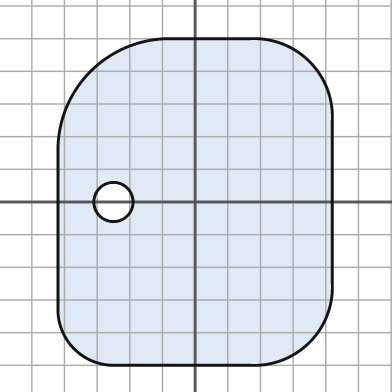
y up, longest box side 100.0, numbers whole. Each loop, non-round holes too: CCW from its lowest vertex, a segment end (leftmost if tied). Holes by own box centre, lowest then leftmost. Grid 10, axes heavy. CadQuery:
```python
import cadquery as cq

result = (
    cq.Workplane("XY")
    .moveTo(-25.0, -50.0)
    .lineTo(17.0, -50.0)
    .threePointArc((35.0, -43.0), (42.0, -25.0))
    .lineTo(42.0, 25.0)
    .threePointArc((35.0, 43.0), (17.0, 50.0))
    .lineTo(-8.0, 50.0)
    .threePointArc((-32.0, 40.0), (-42.0, 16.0))
    .lineTo(-42.0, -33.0)
    .threePointArc((-37.0, -45.0), (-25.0, -50.0))
    .close()
    .moveTo(-25.0, 0.0)
    .circle(6.0)
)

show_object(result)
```